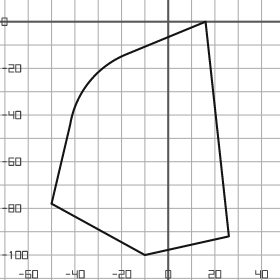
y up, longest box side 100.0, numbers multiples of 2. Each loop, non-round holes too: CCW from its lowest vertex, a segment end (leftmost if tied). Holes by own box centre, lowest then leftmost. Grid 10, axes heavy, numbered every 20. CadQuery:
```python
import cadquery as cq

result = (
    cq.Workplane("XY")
    .moveTo(-10.0, -100.0)
    .lineTo(26.0, -92.0)
    .lineTo(16.0, 0.0)
    .lineTo(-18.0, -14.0)
    .threePointArc((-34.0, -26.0), (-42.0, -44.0))
    .lineTo(-50.0, -78.0)
    .close()
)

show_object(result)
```